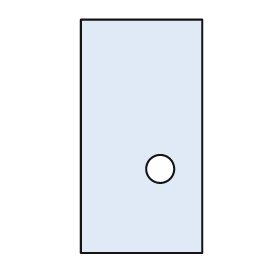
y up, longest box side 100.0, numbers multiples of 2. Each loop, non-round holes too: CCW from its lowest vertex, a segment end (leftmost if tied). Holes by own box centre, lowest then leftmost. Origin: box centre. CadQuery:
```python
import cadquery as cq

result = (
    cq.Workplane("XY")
    .moveTo(-26.0, -50.0)
    .lineTo(26.0, -50.0)
    .lineTo(26.0, 50.0)
    .lineTo(-26.0, 50.0)
    .close()
    .moveTo(8.0, -14.0)
    .circle(6.0)
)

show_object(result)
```